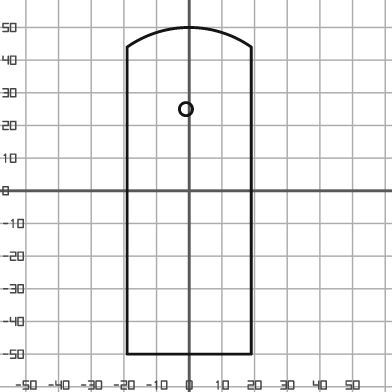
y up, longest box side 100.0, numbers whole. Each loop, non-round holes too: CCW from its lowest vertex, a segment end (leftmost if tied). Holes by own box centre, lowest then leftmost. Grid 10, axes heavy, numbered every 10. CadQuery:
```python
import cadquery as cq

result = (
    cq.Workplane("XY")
    .moveTo(-19.0, -50.0)
    .lineTo(19.0, -50.0)
    .lineTo(19.0, 44.0)
    .threePointArc((0.0, 50.0), (-19.0, 44.0))
    .close()
    .moveTo(-1.0, 25.0)
    .circle(2.0)
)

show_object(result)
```